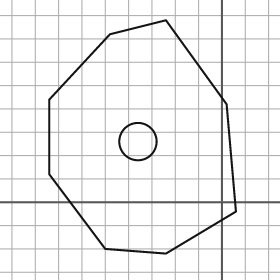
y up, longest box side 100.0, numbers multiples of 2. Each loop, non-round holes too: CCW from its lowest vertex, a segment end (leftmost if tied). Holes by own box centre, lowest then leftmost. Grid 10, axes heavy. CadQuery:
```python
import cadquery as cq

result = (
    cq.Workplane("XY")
    .moveTo(-24.0, -22.0)
    .lineTo(6.0, -4.0)
    .lineTo(2.0, 42.0)
    .lineTo(-24.0, 78.0)
    .lineTo(-48.0, 72.0)
    .lineTo(-74.0, 44.0)
    .lineTo(-74.0, 12.0)
    .lineTo(-50.0, -20.0)
    .close()
    .moveTo(-36.0, 26.0)
    .circle(8.0)
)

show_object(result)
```